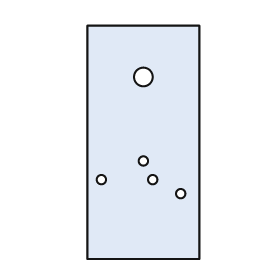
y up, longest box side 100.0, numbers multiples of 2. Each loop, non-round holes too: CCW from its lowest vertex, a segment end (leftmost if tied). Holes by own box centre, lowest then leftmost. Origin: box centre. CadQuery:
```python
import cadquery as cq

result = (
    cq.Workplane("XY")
    .moveTo(-24.0, -50.0)
    .lineTo(24.0, -50.0)
    .lineTo(24.0, 50.0)
    .lineTo(-24.0, 50.0)
    .close()
    .moveTo(16.0, -22.0)
    .circle(2.0)
    .moveTo(-18.0, -16.0)
    .circle(2.0)
    .moveTo(4.0, -16.0)
    .circle(2.0)
    .moveTo(0.0, -8.0)
    .circle(2.0)
    .moveTo(0.0, 28.0)
    .circle(4.0)
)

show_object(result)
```